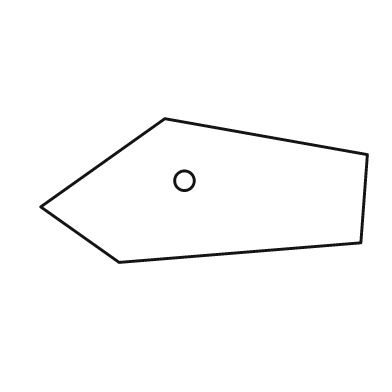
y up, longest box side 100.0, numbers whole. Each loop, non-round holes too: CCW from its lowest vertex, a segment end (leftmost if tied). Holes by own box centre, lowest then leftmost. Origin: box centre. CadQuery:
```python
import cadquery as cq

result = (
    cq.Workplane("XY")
    .moveTo(-26.0, -22.0)
    .lineTo(48.0, -16.0)
    .lineTo(50.0, 11.0)
    .lineTo(-12.0, 22.0)
    .lineTo(-50.0, -5.0)
    .close()
    .moveTo(-6.0, 3.0)
    .circle(3.0)
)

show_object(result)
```